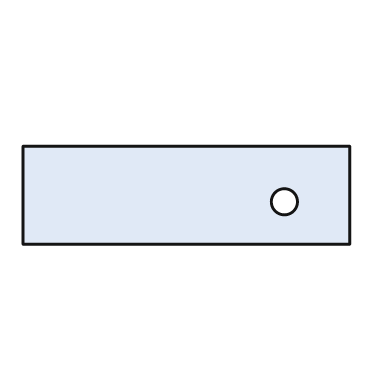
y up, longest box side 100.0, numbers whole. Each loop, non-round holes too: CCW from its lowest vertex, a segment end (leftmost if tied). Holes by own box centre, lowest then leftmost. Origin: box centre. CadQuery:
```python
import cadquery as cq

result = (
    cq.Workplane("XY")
    .moveTo(-50.0, -15.0)
    .lineTo(50.0, -15.0)
    .lineTo(50.0, 15.0)
    .lineTo(-50.0, 15.0)
    .close()
    .moveTo(30.0, -2.0)
    .circle(4.0)
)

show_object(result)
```